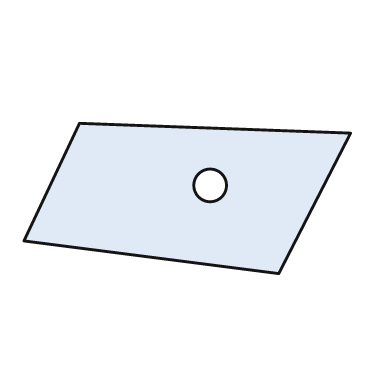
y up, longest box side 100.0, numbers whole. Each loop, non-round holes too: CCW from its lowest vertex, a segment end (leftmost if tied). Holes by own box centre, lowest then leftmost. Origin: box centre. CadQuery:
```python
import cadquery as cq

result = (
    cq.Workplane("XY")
    .moveTo(28.0, -23.0)
    .lineTo(50.0, 20.0)
    .lineTo(-33.0, 23.0)
    .lineTo(-50.0, -13.0)
    .close()
    .moveTo(7.0, 4.0)
    .circle(5.0)
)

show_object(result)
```